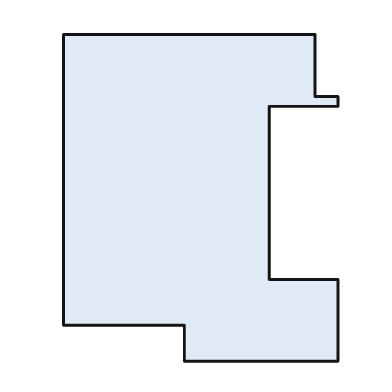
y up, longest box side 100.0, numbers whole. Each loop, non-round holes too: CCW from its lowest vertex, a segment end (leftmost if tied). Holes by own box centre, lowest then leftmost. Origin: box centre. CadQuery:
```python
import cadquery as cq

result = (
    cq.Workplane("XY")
    .moveTo(-5.0, -50.0)
    .lineTo(42.0, -50.0)
    .lineTo(42.0, -25.0)
    .lineTo(21.0, -25.0)
    .lineTo(21.0, 28.0)
    .lineTo(42.0, 28.0)
    .lineTo(42.0, 31.0)
    .lineTo(35.0, 31.0)
    .lineTo(35.0, 50.0)
    .lineTo(-42.0, 50.0)
    .lineTo(-42.0, -39.0)
    .lineTo(-5.0, -39.0)
    .close()
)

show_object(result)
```